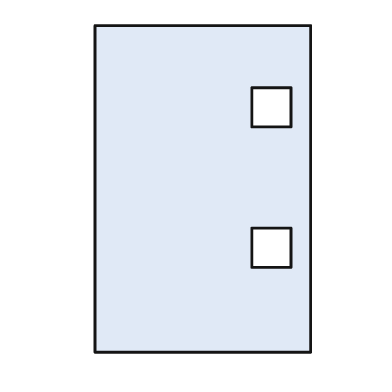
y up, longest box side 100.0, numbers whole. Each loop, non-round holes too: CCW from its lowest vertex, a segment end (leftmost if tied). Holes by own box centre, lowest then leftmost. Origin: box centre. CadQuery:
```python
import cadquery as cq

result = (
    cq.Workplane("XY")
    .moveTo(-33.0, -50.0)
    .lineTo(33.0, -50.0)
    .lineTo(33.0, 50.0)
    .lineTo(-33.0, 50.0)
    .close()
    .moveTo(15.0, -24.0)
    .lineTo(27.0, -24.0)
    .lineTo(27.0, -12.0)
    .lineTo(15.0, -12.0)
    .close()
    .moveTo(15.0, 19.0)
    .lineTo(27.0, 19.0)
    .lineTo(27.0, 31.0)
    .lineTo(15.0, 31.0)
    .close()
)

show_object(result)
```